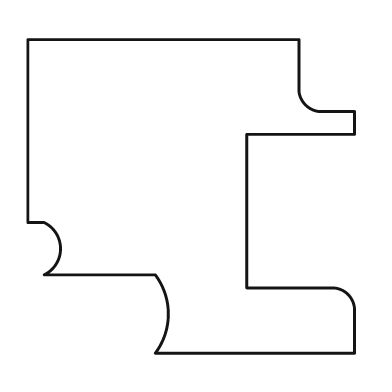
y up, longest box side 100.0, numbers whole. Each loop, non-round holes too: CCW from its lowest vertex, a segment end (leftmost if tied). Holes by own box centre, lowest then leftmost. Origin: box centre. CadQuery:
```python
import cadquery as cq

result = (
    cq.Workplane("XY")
    .moveTo(-11.0, -48.0)
    .lineTo(50.0, -48.0)
    .lineTo(50.0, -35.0)
    .threePointArc((48.0, -30.0), (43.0, -28.0))
    .lineTo(17.0, -28.0)
    .lineTo(17.0, 19.0)
    .lineTo(50.0, 19.0)
    .lineTo(50.0, 26.0)
    .lineTo(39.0, 26.0)
    .threePointArc((35.0, 28.0), (33.0, 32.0))
    .lineTo(33.0, 48.0)
    .lineTo(-50.0, 48.0)
    .lineTo(-50.0, -8.0)
    .lineTo(-45.0, -8.0)
    .threePointArc((-40.0, -16.0), (-45.0, -24.0))
    .lineTo(-11.0, -24.0)
    .threePointArc((-7.0, -36.0), (-11.0, -48.0))
    .close()
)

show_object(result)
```